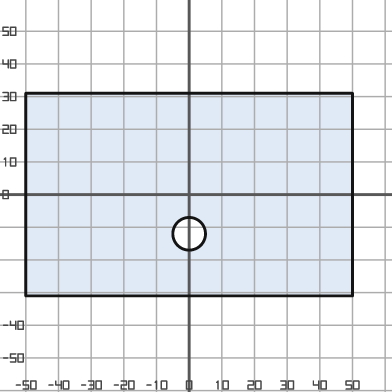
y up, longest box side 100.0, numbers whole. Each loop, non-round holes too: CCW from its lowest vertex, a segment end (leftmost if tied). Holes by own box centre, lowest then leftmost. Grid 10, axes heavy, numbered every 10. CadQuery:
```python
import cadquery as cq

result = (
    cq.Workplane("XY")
    .moveTo(-50.0, -31.0)
    .lineTo(50.0, -31.0)
    .lineTo(50.0, 31.0)
    .lineTo(-50.0, 31.0)
    .close()
    .moveTo(0.0, -12.0)
    .circle(5.0)
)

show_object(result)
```